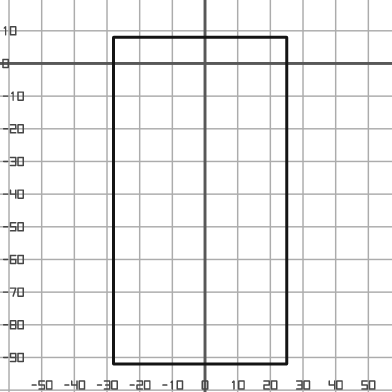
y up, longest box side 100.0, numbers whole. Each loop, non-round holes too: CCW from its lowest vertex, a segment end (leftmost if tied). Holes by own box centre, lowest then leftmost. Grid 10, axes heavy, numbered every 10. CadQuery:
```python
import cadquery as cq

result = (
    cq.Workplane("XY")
    .moveTo(-28.0, -92.0)
    .lineTo(25.0, -92.0)
    .lineTo(25.0, 8.0)
    .lineTo(-28.0, 8.0)
    .close()
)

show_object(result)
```